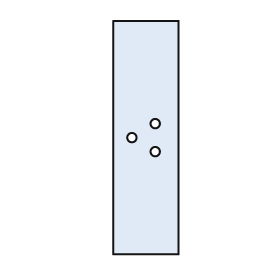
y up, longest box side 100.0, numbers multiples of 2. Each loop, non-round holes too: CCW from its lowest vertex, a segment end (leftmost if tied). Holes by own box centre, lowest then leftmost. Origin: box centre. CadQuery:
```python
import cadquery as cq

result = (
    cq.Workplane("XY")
    .moveTo(-14.0, -50.0)
    .lineTo(14.0, -50.0)
    .lineTo(14.0, 50.0)
    .lineTo(-14.0, 50.0)
    .close()
    .moveTo(4.0, -6.0)
    .circle(2.0)
    .moveTo(-6.0, 0.0)
    .circle(2.0)
    .moveTo(4.0, 6.0)
    .circle(2.0)
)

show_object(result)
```